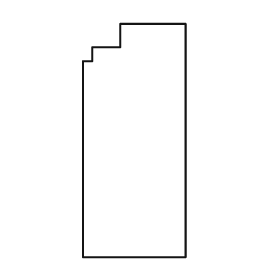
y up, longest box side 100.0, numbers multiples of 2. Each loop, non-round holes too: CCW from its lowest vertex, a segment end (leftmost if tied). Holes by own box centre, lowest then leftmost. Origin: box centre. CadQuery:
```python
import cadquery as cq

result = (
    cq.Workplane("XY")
    .moveTo(-22.0, -50.0)
    .lineTo(22.0, -50.0)
    .lineTo(22.0, 50.0)
    .lineTo(-6.0, 50.0)
    .lineTo(-6.0, 40.0)
    .lineTo(-18.0, 40.0)
    .lineTo(-18.0, 34.0)
    .lineTo(-22.0, 34.0)
    .close()
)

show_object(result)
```